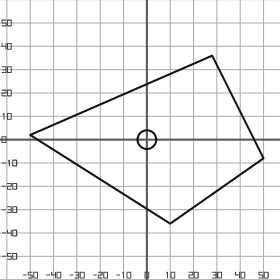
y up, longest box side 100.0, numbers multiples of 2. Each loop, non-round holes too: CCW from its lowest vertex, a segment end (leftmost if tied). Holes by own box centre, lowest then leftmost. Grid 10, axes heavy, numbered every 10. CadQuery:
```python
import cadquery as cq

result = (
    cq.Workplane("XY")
    .moveTo(10.0, -36.0)
    .lineTo(50.0, -8.0)
    .lineTo(28.0, 36.0)
    .lineTo(-50.0, 2.0)
    .close()
    .moveTo(0.0, 0.0)
    .circle(4.0)
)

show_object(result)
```